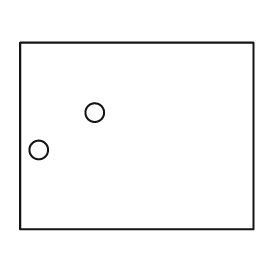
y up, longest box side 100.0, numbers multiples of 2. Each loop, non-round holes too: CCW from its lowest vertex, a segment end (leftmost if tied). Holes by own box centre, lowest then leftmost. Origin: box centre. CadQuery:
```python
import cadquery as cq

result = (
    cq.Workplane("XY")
    .moveTo(-50.0, -40.0)
    .lineTo(50.0, -40.0)
    .lineTo(50.0, 40.0)
    .lineTo(-50.0, 40.0)
    .close()
    .moveTo(-42.0, -6.0)
    .circle(4.0)
    .moveTo(-18.0, 10.0)
    .circle(4.0)
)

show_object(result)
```